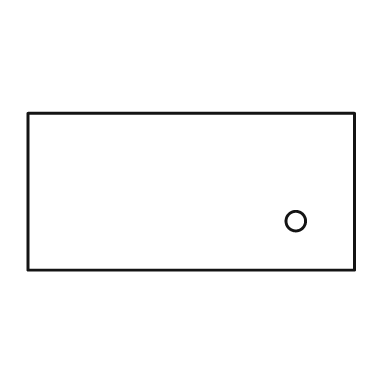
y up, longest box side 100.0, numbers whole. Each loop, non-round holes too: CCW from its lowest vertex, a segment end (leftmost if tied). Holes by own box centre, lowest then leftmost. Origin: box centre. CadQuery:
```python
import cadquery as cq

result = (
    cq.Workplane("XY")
    .moveTo(-50.0, -24.0)
    .lineTo(50.0, -24.0)
    .lineTo(50.0, 24.0)
    .lineTo(-50.0, 24.0)
    .close()
    .moveTo(32.0, -9.0)
    .circle(3.0)
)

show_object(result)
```